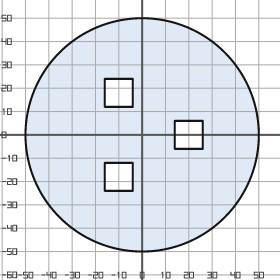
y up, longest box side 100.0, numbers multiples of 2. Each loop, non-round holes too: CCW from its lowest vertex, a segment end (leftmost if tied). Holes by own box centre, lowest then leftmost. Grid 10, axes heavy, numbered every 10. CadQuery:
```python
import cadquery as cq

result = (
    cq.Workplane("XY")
    .moveTo(0.0, 0.0)
    .circle(50.0)
    .moveTo(-16.0, -24.0)
    .lineTo(-4.0, -24.0)
    .lineTo(-4.0, -12.0)
    .lineTo(-16.0, -12.0)
    .close()
    .moveTo(14.0, -6.0)
    .lineTo(26.0, -6.0)
    .lineTo(26.0, 6.0)
    .lineTo(14.0, 6.0)
    .close()
    .moveTo(-16.0, 12.0)
    .lineTo(-4.0, 12.0)
    .lineTo(-4.0, 24.0)
    .lineTo(-16.0, 24.0)
    .close()
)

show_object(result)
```